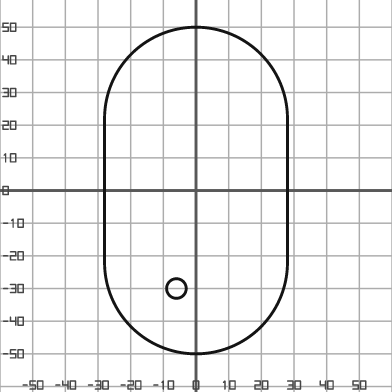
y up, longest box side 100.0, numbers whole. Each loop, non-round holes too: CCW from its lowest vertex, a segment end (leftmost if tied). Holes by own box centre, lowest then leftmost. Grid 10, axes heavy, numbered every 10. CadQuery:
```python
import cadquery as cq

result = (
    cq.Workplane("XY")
    .moveTo(-28.0, -22.0)
    .threePointArc((0.0, -50.0), (28.0, -22.0))
    .lineTo(28.0, 22.0)
    .threePointArc((0.0, 50.0), (-28.0, 22.0))
    .close()
    .moveTo(-6.0, -30.0)
    .circle(3.0)
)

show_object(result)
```